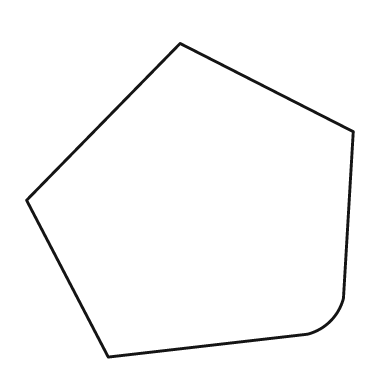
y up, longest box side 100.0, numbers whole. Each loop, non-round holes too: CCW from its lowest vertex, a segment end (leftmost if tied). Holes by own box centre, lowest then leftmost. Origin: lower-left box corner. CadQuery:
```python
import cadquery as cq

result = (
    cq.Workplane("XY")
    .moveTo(25.0, 0.0)
    .lineTo(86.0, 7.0)
    .threePointArc((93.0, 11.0), (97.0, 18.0))
    .lineTo(100.0, 69.0)
    .lineTo(47.0, 96.0)
    .lineTo(0.0, 48.0)
    .close()
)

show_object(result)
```